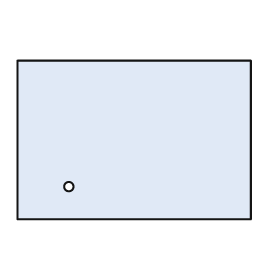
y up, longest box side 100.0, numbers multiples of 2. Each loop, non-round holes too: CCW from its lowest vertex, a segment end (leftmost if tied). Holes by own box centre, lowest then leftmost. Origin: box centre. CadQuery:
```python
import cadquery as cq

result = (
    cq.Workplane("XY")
    .moveTo(-50.0, -34.0)
    .lineTo(50.0, -34.0)
    .lineTo(50.0, 34.0)
    .lineTo(-50.0, 34.0)
    .close()
    .moveTo(-28.0, -20.0)
    .circle(2.0)
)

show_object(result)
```